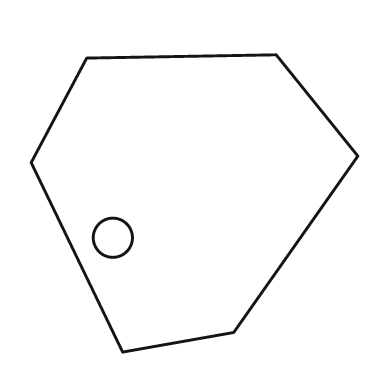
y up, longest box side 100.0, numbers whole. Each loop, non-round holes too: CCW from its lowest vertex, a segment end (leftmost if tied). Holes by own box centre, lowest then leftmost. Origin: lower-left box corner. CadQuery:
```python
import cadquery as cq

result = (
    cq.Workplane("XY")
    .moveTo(28.0, 0.0)
    .lineTo(62.0, 6.0)
    .lineTo(100.0, 60.0)
    .lineTo(75.0, 91.0)
    .lineTo(17.0, 90.0)
    .lineTo(0.0, 58.0)
    .close()
    .moveTo(25.0, 35.0)
    .circle(6.0)
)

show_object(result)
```